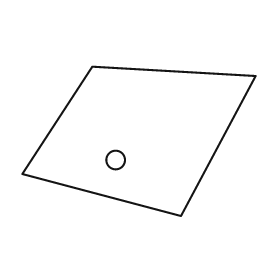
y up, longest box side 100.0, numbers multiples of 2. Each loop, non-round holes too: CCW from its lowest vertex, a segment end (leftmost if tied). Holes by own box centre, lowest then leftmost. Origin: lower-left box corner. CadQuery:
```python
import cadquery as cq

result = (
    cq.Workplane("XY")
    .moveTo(68.0, 0.0)
    .lineTo(100.0, 60.0)
    .lineTo(30.0, 64.0)
    .lineTo(0.0, 18.0)
    .close()
    .moveTo(40.0, 24.0)
    .circle(4.0)
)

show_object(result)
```